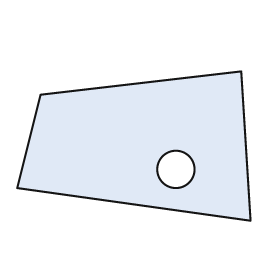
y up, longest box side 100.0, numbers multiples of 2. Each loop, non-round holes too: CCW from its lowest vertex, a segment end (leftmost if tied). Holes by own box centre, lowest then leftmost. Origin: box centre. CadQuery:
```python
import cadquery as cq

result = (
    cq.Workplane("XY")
    .moveTo(50.0, -32.0)
    .lineTo(46.0, 32.0)
    .lineTo(-40.0, 22.0)
    .lineTo(-50.0, -18.0)
    .close()
    .moveTo(18.0, -10.0)
    .circle(8.0)
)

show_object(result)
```